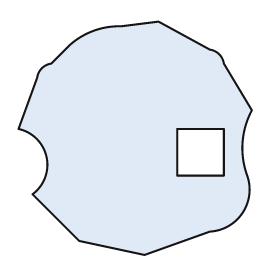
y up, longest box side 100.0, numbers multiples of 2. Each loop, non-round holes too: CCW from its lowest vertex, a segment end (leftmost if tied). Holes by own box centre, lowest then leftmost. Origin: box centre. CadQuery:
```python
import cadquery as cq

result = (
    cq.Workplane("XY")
    .moveTo(4.0, -50.0)
    .lineTo(32.0, -40.0)
    .threePointArc((46.0, -32.0), (48.0, -16.0))
    .threePointArc((46.0, -2.0), (50.0, 12.0))
    .lineTo(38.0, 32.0)
    .threePointArc((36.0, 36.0), (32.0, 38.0))
    .lineTo(10.0, 50.0)
    .lineTo(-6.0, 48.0)
    .threePointArc((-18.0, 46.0), (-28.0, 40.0))
    .lineTo(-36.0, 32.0)
    .threePointArc((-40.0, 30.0), (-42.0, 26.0))
    .lineTo(-50.0, 4.0)
    .threePointArc((-38.0, -8.0), (-44.0, -24.0))
    .lineTo(-24.0, -44.0)
    .close()
    .moveTo(18.0, -16.0)
    .lineTo(38.0, -16.0)
    .lineTo(38.0, 4.0)
    .lineTo(18.0, 4.0)
    .close()
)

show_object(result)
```